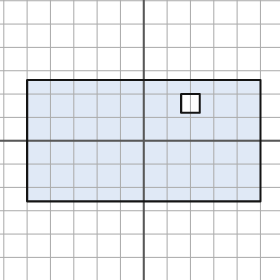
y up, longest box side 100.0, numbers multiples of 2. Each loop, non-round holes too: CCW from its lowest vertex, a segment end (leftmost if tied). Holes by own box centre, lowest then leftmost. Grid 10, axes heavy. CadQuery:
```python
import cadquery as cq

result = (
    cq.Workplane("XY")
    .moveTo(-50.0, -26.0)
    .lineTo(50.0, -26.0)
    .lineTo(50.0, 26.0)
    .lineTo(-50.0, 26.0)
    .close()
    .moveTo(16.0, 12.0)
    .lineTo(24.0, 12.0)
    .lineTo(24.0, 20.0)
    .lineTo(16.0, 20.0)
    .close()
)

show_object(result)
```